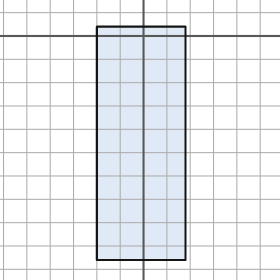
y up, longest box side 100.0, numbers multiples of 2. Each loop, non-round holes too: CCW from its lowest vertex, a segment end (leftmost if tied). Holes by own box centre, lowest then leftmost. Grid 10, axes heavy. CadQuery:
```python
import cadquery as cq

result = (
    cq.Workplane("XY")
    .moveTo(-20.0, -96.0)
    .lineTo(18.0, -96.0)
    .lineTo(18.0, 4.0)
    .lineTo(-20.0, 4.0)
    .close()
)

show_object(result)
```